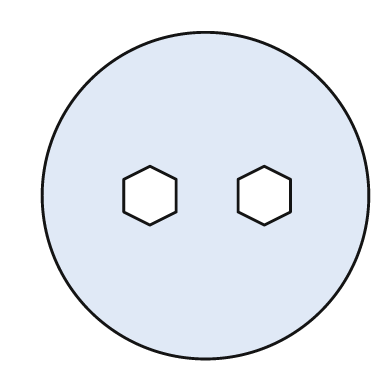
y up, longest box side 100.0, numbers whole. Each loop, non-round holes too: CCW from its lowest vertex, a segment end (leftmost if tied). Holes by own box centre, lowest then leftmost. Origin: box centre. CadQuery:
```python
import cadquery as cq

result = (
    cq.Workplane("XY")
    .moveTo(0.0, 0.0)
    .circle(50.0)
    .moveTo(-17.0, -9.0)
    .lineTo(-9.0, -5.0)
    .lineTo(-9.0, 5.0)
    .lineTo(-17.0, 9.0)
    .lineTo(-25.0, 5.0)
    .lineTo(-25.0, -5.0)
    .close()
    .moveTo(18.0, -9.0)
    .lineTo(26.0, -5.0)
    .lineTo(26.0, 5.0)
    .lineTo(18.0, 9.0)
    .lineTo(10.0, 5.0)
    .lineTo(10.0, -5.0)
    .close()
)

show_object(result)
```